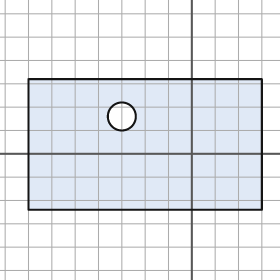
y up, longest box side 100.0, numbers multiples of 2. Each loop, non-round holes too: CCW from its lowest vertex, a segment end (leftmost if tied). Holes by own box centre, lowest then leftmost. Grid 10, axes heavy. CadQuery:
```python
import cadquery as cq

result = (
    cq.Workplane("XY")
    .moveTo(-70.0, -24.0)
    .lineTo(30.0, -24.0)
    .lineTo(30.0, 32.0)
    .lineTo(-70.0, 32.0)
    .close()
    .moveTo(-30.0, 16.0)
    .circle(6.0)
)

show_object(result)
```